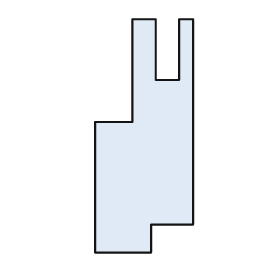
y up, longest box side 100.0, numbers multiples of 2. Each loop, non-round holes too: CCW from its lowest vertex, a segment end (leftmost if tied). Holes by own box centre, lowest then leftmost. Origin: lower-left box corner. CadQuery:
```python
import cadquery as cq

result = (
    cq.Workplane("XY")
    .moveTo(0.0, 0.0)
    .lineTo(24.0, 0.0)
    .lineTo(24.0, 12.0)
    .lineTo(42.0, 12.0)
    .lineTo(42.0, 100.0)
    .lineTo(36.0, 100.0)
    .lineTo(36.0, 74.0)
    .lineTo(26.0, 74.0)
    .lineTo(26.0, 100.0)
    .lineTo(16.0, 100.0)
    .lineTo(16.0, 56.0)
    .lineTo(0.0, 56.0)
    .close()
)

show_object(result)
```